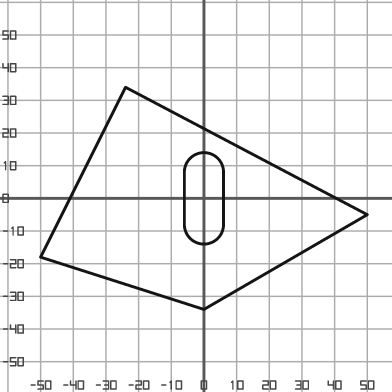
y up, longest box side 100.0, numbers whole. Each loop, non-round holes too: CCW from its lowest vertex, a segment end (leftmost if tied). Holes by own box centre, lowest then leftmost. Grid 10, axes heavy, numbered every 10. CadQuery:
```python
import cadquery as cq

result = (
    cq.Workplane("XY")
    .moveTo(0.0, -34.0)
    .lineTo(50.0, -5.0)
    .lineTo(-24.0, 34.0)
    .lineTo(-50.0, -18.0)
    .close()
    .moveTo(-6.0, -8.0)
    .threePointArc((0.0, -14.0), (6.0, -8.0))
    .lineTo(6.0, 8.0)
    .threePointArc((0.0, 14.0), (-6.0, 8.0))
    .close()
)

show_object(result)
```